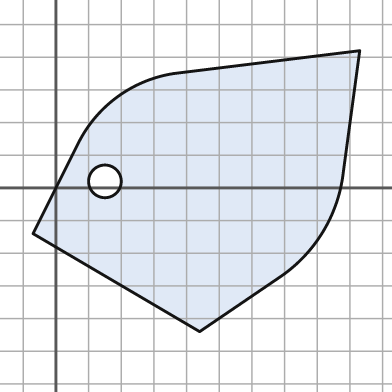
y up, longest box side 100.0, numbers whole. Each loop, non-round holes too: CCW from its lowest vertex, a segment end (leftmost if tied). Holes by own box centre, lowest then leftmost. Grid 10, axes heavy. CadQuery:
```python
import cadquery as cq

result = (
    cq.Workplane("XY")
    .moveTo(44.0, -44.0)
    .lineTo(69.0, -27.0)
    .threePointArc((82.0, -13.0), (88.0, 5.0))
    .lineTo(93.0, 42.0)
    .lineTo(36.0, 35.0)
    .threePointArc((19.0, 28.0), (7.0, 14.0))
    .lineTo(-7.0, -14.0)
    .close()
    .moveTo(15.0, 2.0)
    .circle(5.0)
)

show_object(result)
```